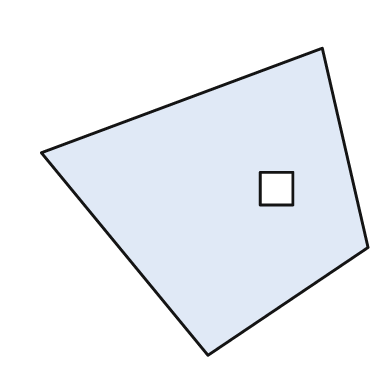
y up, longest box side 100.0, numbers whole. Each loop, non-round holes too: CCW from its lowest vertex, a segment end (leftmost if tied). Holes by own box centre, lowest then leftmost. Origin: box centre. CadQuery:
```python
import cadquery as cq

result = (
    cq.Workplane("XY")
    .moveTo(1.0, -47.0)
    .lineTo(50.0, -14.0)
    .lineTo(36.0, 47.0)
    .lineTo(-50.0, 15.0)
    .close()
    .moveTo(17.0, -1.0)
    .lineTo(27.0, -1.0)
    .lineTo(27.0, 9.0)
    .lineTo(17.0, 9.0)
    .close()
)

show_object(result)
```